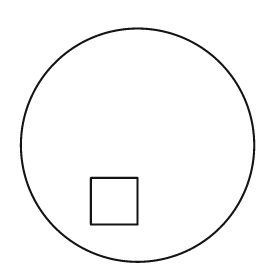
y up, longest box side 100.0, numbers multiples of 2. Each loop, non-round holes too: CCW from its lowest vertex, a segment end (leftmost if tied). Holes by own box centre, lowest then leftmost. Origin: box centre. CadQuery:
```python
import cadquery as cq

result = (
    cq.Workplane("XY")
    .moveTo(0.0, 0.0)
    .circle(50.0)
    .moveTo(-20.0, -34.0)
    .lineTo(0.0, -34.0)
    .lineTo(0.0, -14.0)
    .lineTo(-20.0, -14.0)
    .close()
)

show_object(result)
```